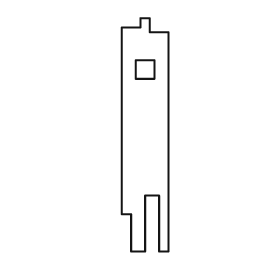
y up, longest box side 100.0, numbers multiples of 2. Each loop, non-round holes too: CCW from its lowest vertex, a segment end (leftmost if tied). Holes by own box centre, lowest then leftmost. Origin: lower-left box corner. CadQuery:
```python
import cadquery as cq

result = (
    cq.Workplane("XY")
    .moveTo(4.0, 0.0)
    .lineTo(10.0, 0.0)
    .lineTo(10.0, 24.0)
    .lineTo(16.0, 24.0)
    .lineTo(16.0, 0.0)
    .lineTo(20.0, 0.0)
    .lineTo(20.0, 94.0)
    .lineTo(12.0, 94.0)
    .lineTo(12.0, 100.0)
    .lineTo(8.0, 100.0)
    .lineTo(8.0, 96.0)
    .lineTo(0.0, 96.0)
    .lineTo(0.0, 16.0)
    .lineTo(4.0, 16.0)
    .close()
    .moveTo(6.0, 74.0)
    .lineTo(14.0, 74.0)
    .lineTo(14.0, 82.0)
    .lineTo(6.0, 82.0)
    .close()
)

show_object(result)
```